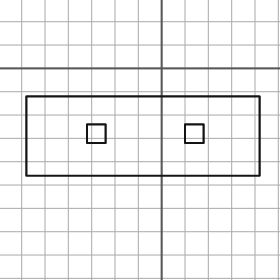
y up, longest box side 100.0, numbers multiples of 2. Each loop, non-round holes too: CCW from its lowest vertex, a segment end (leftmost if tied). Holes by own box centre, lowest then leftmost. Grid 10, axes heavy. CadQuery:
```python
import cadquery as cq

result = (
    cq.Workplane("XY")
    .moveTo(-58.0, -46.0)
    .lineTo(42.0, -46.0)
    .lineTo(42.0, -12.0)
    .lineTo(-58.0, -12.0)
    .close()
    .moveTo(-32.0, -32.0)
    .lineTo(-24.0, -32.0)
    .lineTo(-24.0, -24.0)
    .lineTo(-32.0, -24.0)
    .close()
    .moveTo(10.0, -32.0)
    .lineTo(18.0, -32.0)
    .lineTo(18.0, -24.0)
    .lineTo(10.0, -24.0)
    .close()
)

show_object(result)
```